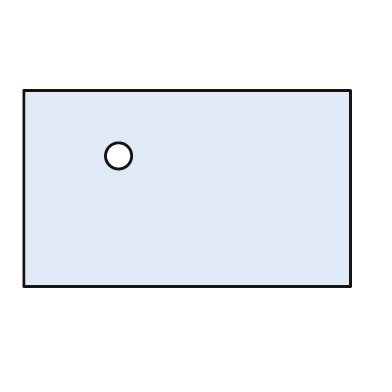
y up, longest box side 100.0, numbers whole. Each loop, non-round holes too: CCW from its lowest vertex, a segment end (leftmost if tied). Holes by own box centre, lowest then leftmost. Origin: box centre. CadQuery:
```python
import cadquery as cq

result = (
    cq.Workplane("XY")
    .moveTo(-50.0, -30.0)
    .lineTo(50.0, -30.0)
    .lineTo(50.0, 30.0)
    .lineTo(-50.0, 30.0)
    .close()
    .moveTo(-21.0, 10.0)
    .circle(4.0)
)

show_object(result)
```